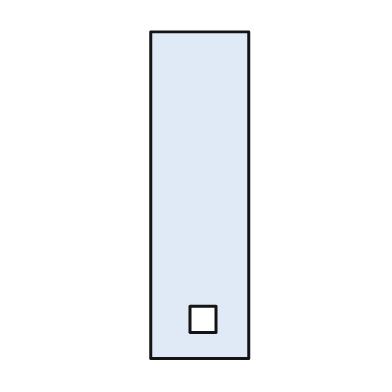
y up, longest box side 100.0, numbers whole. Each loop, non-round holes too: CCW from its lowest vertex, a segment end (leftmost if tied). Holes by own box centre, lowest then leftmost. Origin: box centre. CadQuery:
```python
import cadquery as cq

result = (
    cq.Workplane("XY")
    .moveTo(-15.0, -50.0)
    .lineTo(15.0, -50.0)
    .lineTo(15.0, 50.0)
    .lineTo(-15.0, 50.0)
    .close()
    .moveTo(-3.0, -42.0)
    .lineTo(5.0, -42.0)
    .lineTo(5.0, -34.0)
    .lineTo(-3.0, -34.0)
    .close()
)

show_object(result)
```